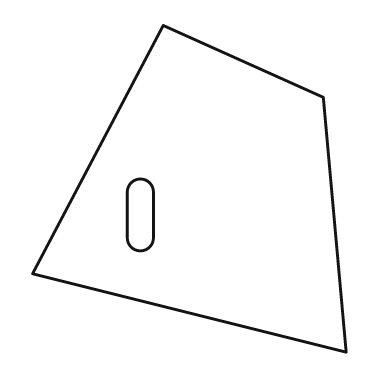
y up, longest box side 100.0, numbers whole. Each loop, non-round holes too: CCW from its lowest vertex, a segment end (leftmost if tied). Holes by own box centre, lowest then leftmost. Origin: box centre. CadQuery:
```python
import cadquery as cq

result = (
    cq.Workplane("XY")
    .moveTo(48.0, -50.0)
    .lineTo(41.0, 28.0)
    .lineTo(-8.0, 50.0)
    .lineTo(-48.0, -26.0)
    .close()
    .moveTo(-19.0, -15.0)
    .threePointArc((-15.0, -19.0), (-11.0, -15.0))
    .lineTo(-11.0, -1.0)
    .threePointArc((-15.0, 3.0), (-19.0, -1.0))
    .close()
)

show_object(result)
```